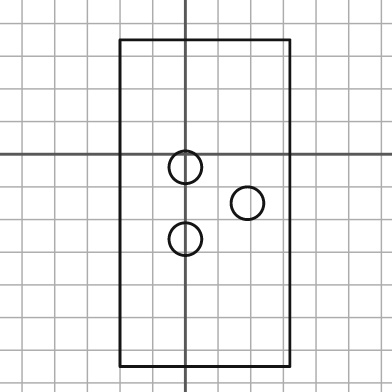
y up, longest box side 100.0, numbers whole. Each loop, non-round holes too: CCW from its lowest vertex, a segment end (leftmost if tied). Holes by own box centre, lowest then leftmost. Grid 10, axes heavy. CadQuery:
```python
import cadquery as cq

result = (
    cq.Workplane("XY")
    .moveTo(-20.0, -65.0)
    .lineTo(32.0, -65.0)
    .lineTo(32.0, 35.0)
    .lineTo(-20.0, 35.0)
    .close()
    .moveTo(0.0, -26.0)
    .circle(5.0)
    .moveTo(19.0, -15.0)
    .circle(5.0)
    .moveTo(0.0, -4.0)
    .circle(5.0)
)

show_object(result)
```